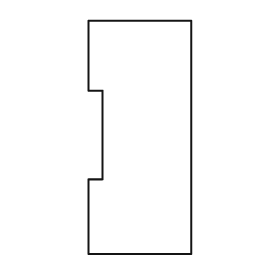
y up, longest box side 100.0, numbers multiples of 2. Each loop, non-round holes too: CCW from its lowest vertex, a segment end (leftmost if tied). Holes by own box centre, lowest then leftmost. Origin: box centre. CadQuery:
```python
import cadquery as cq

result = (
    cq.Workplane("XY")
    .moveTo(-22.0, -50.0)
    .lineTo(22.0, -50.0)
    .lineTo(22.0, 50.0)
    .lineTo(-22.0, 50.0)
    .lineTo(-22.0, 20.0)
    .lineTo(-16.0, 20.0)
    .lineTo(-16.0, -18.0)
    .lineTo(-22.0, -18.0)
    .close()
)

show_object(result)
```